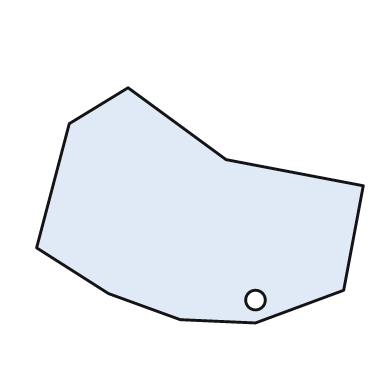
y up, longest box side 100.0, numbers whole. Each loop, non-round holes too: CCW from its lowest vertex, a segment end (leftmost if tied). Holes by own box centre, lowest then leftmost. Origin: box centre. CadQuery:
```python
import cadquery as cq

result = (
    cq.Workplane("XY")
    .moveTo(17.0, -36.0)
    .lineTo(44.0, -26.0)
    .lineTo(50.0, 6.0)
    .lineTo(8.0, 14.0)
    .lineTo(-22.0, 36.0)
    .lineTo(-40.0, 25.0)
    .lineTo(-50.0, -13.0)
    .lineTo(-28.0, -27.0)
    .lineTo(-6.0, -35.0)
    .close()
    .moveTo(17.0, -29.0)
    .circle(3.0)
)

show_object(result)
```